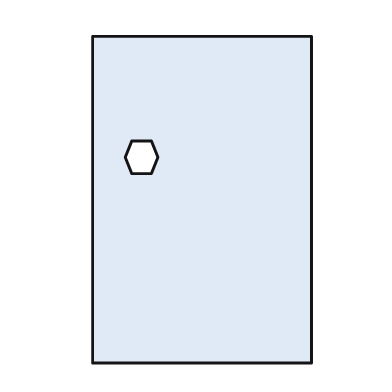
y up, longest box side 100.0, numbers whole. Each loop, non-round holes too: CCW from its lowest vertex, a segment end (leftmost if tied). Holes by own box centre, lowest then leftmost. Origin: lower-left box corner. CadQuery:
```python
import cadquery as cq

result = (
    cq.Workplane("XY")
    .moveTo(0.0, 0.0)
    .lineTo(67.0, 0.0)
    .lineTo(67.0, 100.0)
    .lineTo(0.0, 100.0)
    .close()
    .moveTo(12.0, 58.0)
    .lineTo(18.0, 58.0)
    .lineTo(20.0, 63.0)
    .lineTo(18.0, 68.0)
    .lineTo(12.0, 68.0)
    .lineTo(10.0, 63.0)
    .close()
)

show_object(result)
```